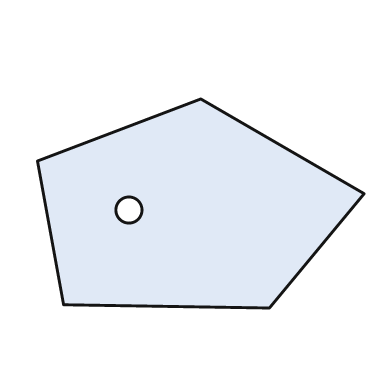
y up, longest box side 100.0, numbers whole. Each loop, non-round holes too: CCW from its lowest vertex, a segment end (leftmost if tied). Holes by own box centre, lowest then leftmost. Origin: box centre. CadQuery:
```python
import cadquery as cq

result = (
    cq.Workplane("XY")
    .moveTo(21.0, -32.0)
    .lineTo(50.0, 3.0)
    .lineTo(0.0, 32.0)
    .lineTo(-50.0, 13.0)
    .lineTo(-42.0, -31.0)
    .close()
    .moveTo(-22.0, -2.0)
    .circle(4.0)
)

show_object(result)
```